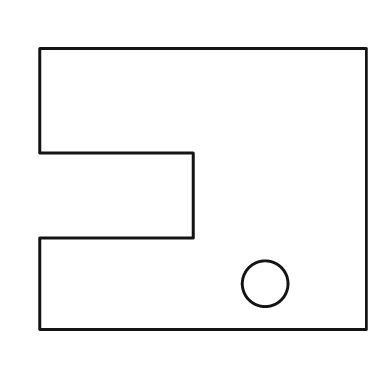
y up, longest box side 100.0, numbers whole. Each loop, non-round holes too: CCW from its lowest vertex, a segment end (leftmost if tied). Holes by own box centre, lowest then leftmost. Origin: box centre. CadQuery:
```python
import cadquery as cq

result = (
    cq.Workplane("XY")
    .moveTo(-50.0, -43.0)
    .lineTo(50.0, -43.0)
    .lineTo(50.0, 43.0)
    .lineTo(-50.0, 43.0)
    .lineTo(-50.0, 11.0)
    .lineTo(-3.0, 11.0)
    .lineTo(-3.0, -15.0)
    .lineTo(-50.0, -15.0)
    .close()
    .moveTo(19.0, -29.0)
    .circle(7.0)
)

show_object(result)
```